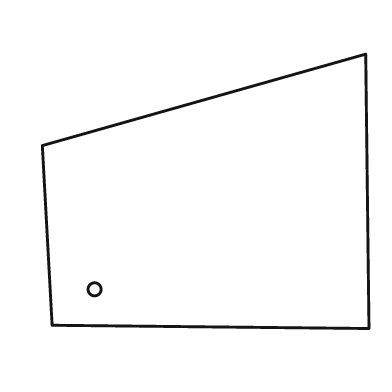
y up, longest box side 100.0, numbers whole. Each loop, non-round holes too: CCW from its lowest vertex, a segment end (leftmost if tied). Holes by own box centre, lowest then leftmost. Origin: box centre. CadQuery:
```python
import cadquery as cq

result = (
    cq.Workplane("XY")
    .moveTo(50.0, -42.0)
    .lineTo(49.0, 42.0)
    .lineTo(-50.0, 14.0)
    .lineTo(-47.0, -41.0)
    .close()
    .moveTo(-34.0, -30.0)
    .circle(2.0)
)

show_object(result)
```